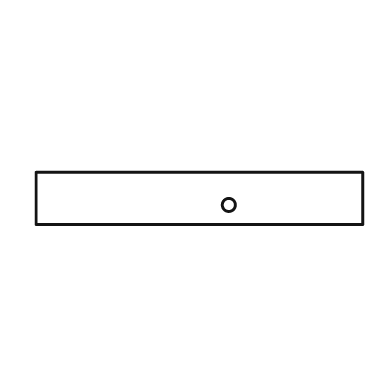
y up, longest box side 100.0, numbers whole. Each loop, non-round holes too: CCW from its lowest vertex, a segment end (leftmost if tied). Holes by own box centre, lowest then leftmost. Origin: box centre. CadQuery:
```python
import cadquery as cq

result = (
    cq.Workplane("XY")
    .moveTo(-50.0, -8.0)
    .lineTo(50.0, -8.0)
    .lineTo(50.0, 8.0)
    .lineTo(-50.0, 8.0)
    .close()
    .moveTo(9.0, -2.0)
    .circle(2.0)
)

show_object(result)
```